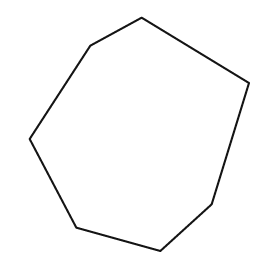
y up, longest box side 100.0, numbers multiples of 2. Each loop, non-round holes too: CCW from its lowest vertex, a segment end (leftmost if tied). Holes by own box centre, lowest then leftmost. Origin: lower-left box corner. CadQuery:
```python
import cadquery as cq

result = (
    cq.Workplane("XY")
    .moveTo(56.0, 0.0)
    .lineTo(78.0, 20.0)
    .lineTo(94.0, 72.0)
    .lineTo(48.0, 100.0)
    .lineTo(26.0, 88.0)
    .lineTo(0.0, 48.0)
    .lineTo(20.0, 10.0)
    .close()
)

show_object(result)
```